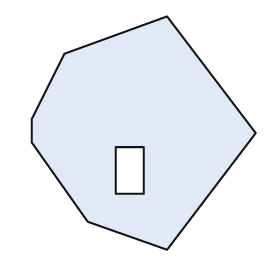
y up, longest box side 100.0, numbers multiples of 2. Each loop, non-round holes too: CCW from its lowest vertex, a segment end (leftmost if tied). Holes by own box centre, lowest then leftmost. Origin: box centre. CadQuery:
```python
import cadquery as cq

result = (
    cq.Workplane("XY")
    .moveTo(10.0, -50.0)
    .lineTo(48.0, 0.0)
    .lineTo(10.0, 50.0)
    .lineTo(-34.0, 34.0)
    .lineTo(-48.0, 6.0)
    .lineTo(-48.0, -4.0)
    .lineTo(-24.0, -38.0)
    .close()
    .moveTo(-12.0, -26.0)
    .lineTo(0.0, -26.0)
    .lineTo(0.0, -6.0)
    .lineTo(-12.0, -6.0)
    .close()
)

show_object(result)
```